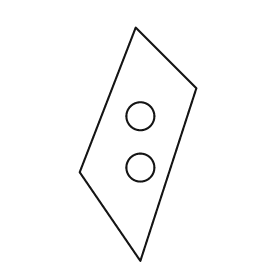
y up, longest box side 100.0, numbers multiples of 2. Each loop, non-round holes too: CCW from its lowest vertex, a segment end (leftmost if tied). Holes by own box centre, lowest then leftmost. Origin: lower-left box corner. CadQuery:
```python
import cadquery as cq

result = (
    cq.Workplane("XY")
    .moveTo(26.0, 0.0)
    .lineTo(50.0, 74.0)
    .lineTo(24.0, 100.0)
    .lineTo(0.0, 38.0)
    .close()
    .moveTo(26.0, 40.0)
    .circle(6.0)
    .moveTo(26.0, 62.0)
    .circle(6.0)
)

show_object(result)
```